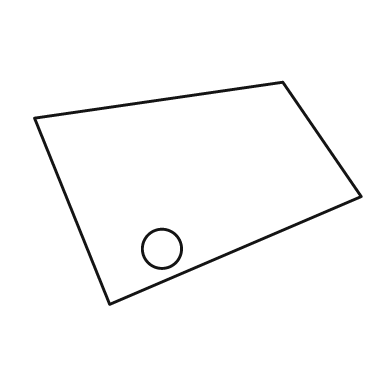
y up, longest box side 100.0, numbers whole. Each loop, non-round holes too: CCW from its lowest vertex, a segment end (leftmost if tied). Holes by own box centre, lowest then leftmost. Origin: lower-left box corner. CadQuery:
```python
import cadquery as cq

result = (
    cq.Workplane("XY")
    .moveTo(23.0, 0.0)
    .lineTo(100.0, 33.0)
    .lineTo(76.0, 68.0)
    .lineTo(0.0, 57.0)
    .close()
    .moveTo(39.0, 17.0)
    .circle(6.0)
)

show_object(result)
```